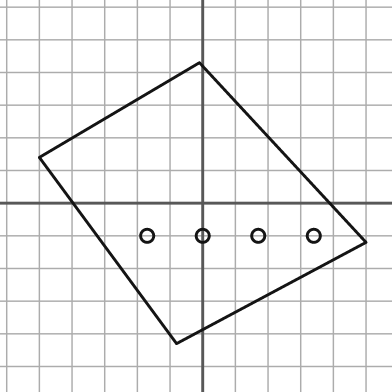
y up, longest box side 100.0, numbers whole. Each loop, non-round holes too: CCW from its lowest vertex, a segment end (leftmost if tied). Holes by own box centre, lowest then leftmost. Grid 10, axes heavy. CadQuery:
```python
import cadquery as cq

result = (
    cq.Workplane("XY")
    .moveTo(-8.0, -43.0)
    .lineTo(50.0, -12.0)
    .lineTo(-1.0, 43.0)
    .lineTo(-50.0, 14.0)
    .close()
    .moveTo(-17.0, -10.0)
    .circle(2.0)
    .moveTo(0.0, -10.0)
    .circle(2.0)
    .moveTo(17.0, -10.0)
    .circle(2.0)
    .moveTo(34.0, -10.0)
    .circle(2.0)
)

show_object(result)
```